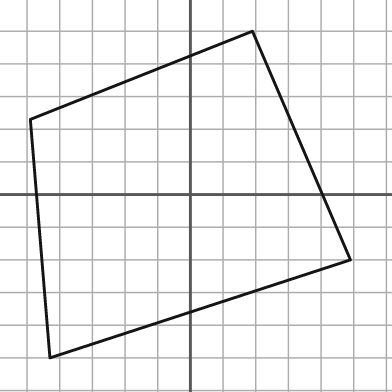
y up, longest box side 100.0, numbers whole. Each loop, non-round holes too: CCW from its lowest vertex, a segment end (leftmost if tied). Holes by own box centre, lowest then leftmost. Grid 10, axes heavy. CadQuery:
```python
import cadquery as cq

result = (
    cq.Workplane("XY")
    .moveTo(-43.0, -50.0)
    .lineTo(49.0, -20.0)
    .lineTo(19.0, 50.0)
    .lineTo(-49.0, 23.0)
    .close()
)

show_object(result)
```